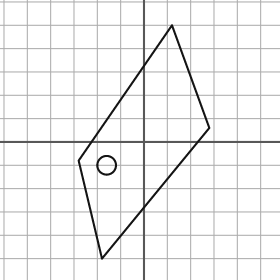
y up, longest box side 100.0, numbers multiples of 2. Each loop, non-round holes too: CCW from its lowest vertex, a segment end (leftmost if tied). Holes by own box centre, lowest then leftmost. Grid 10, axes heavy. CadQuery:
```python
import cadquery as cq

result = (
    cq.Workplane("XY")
    .moveTo(-18.0, -50.0)
    .lineTo(28.0, 6.0)
    .lineTo(12.0, 50.0)
    .lineTo(-28.0, -8.0)
    .close()
    .moveTo(-16.0, -10.0)
    .circle(4.0)
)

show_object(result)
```